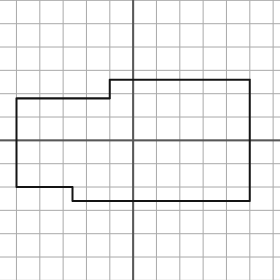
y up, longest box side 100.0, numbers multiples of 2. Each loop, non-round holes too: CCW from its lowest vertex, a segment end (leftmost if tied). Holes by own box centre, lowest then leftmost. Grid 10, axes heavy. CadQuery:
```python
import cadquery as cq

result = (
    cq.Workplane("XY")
    .moveTo(-26.0, -26.0)
    .lineTo(50.0, -26.0)
    .lineTo(50.0, 26.0)
    .lineTo(-10.0, 26.0)
    .lineTo(-10.0, 18.0)
    .lineTo(-50.0, 18.0)
    .lineTo(-50.0, -20.0)
    .lineTo(-26.0, -20.0)
    .close()
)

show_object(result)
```